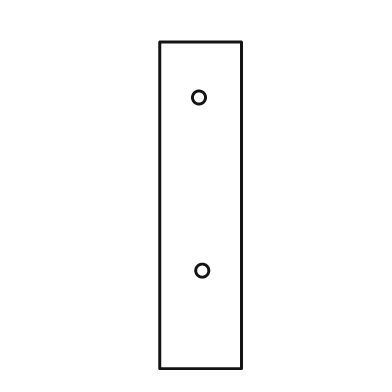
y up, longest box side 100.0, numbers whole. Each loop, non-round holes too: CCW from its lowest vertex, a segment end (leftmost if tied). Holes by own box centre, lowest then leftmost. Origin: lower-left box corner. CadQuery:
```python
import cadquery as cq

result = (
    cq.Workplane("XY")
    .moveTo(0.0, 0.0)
    .lineTo(25.0, 0.0)
    .lineTo(25.0, 100.0)
    .lineTo(0.0, 100.0)
    .close()
    .moveTo(13.0, 30.0)
    .circle(2.0)
    .moveTo(12.0, 83.0)
    .circle(2.0)
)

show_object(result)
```